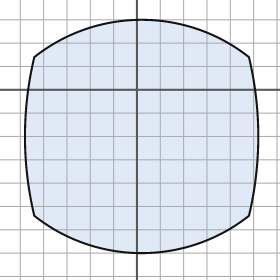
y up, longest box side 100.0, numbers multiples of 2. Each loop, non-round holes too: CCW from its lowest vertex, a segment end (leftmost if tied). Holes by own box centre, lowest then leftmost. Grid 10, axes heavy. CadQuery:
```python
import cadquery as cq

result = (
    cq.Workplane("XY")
    .moveTo(-44.0, -54.0)
    .threePointArc((2.0, -70.0), (48.0, -54.0))
    .threePointArc((52.0, -20.0), (48.0, 14.0))
    .threePointArc((2.0, 30.0), (-44.0, 14.0))
    .threePointArc((-48.0, -20.0), (-44.0, -54.0))
    .close()
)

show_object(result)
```